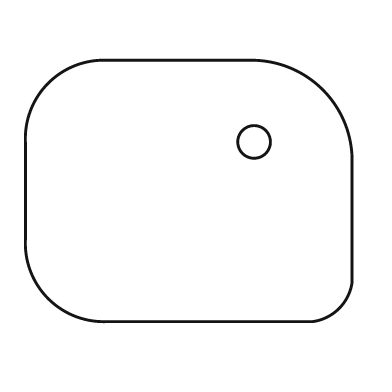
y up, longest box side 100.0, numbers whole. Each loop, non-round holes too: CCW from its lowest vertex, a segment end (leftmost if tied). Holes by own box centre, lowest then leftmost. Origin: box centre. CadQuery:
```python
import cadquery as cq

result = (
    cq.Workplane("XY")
    .moveTo(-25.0, -40.0)
    .lineTo(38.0, -40.0)
    .threePointArc((46.0, -36.0), (50.0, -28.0))
    .lineTo(50.0, 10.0)
    .threePointArc((41.0, 31.0), (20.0, 40.0))
    .lineTo(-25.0, 40.0)
    .threePointArc((-43.0, 33.0), (-50.0, 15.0))
    .lineTo(-50.0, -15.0)
    .threePointArc((-43.0, -33.0), (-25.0, -40.0))
    .close()
    .moveTo(20.0, 15.0)
    .circle(5.0)
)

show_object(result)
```